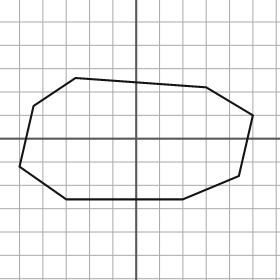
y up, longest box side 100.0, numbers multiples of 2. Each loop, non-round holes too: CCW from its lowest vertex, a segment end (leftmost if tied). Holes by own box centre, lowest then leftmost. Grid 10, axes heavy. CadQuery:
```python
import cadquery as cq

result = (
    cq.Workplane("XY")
    .moveTo(-30.0, -26.0)
    .lineTo(20.0, -26.0)
    .lineTo(44.0, -16.0)
    .lineTo(50.0, 10.0)
    .lineTo(30.0, 22.0)
    .lineTo(-26.0, 26.0)
    .lineTo(-44.0, 14.0)
    .lineTo(-50.0, -12.0)
    .close()
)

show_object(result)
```